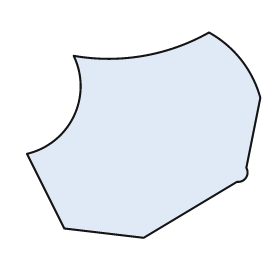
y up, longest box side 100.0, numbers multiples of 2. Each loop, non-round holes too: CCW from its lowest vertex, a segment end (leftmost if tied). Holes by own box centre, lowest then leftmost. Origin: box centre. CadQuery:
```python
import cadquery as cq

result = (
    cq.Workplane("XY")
    .moveTo(0.0, -44.0)
    .lineTo(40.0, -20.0)
    .threePointArc((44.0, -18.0), (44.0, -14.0))
    .lineTo(50.0, 16.0)
    .threePointArc((42.0, 32.0), (28.0, 44.0))
    .threePointArc((0.0, 34.0), (-30.0, 34.0))
    .threePointArc((-30.0, 8.0), (-50.0, -8.0))
    .lineTo(-34.0, -40.0)
    .close()
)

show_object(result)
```